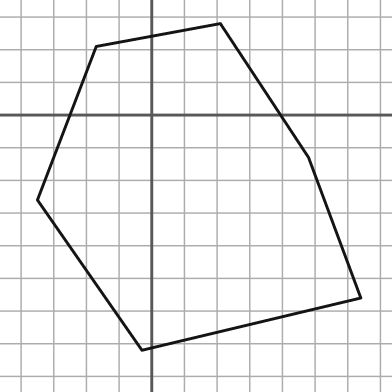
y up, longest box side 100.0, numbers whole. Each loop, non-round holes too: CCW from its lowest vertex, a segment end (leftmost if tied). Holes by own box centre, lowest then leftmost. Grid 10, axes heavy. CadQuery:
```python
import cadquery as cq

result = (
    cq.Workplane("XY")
    .moveTo(-3.0, -72.0)
    .lineTo(64.0, -56.0)
    .lineTo(48.0, -13.0)
    .lineTo(21.0, 28.0)
    .lineTo(-17.0, 21.0)
    .lineTo(-35.0, -26.0)
    .close()
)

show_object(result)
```